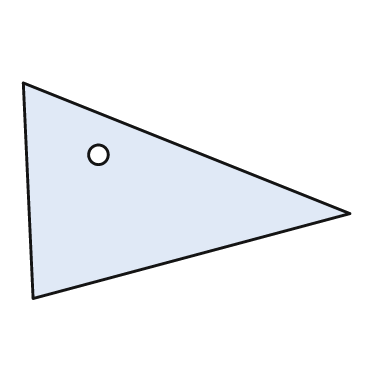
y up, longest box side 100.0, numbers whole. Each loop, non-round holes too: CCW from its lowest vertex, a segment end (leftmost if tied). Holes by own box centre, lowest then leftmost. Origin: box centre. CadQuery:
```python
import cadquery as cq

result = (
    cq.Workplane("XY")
    .moveTo(-47.0, -33.0)
    .lineTo(50.0, -7.0)
    .lineTo(-50.0, 33.0)
    .close()
    .moveTo(-27.0, 11.0)
    .circle(3.0)
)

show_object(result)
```